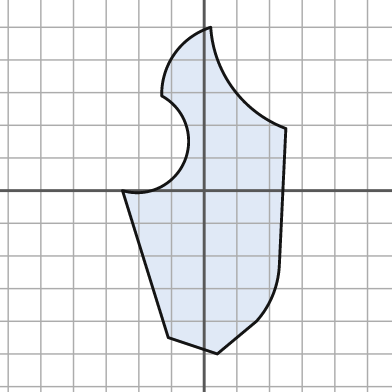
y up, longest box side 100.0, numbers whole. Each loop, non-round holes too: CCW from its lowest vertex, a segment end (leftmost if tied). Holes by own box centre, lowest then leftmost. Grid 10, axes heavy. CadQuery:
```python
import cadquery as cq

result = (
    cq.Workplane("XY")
    .moveTo(4.0, -50.0)
    .lineTo(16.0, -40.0)
    .threePointArc((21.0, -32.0), (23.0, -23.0))
    .lineTo(25.0, 19.0)
    .threePointArc((9.0, 31.0), (2.0, 50.0))
    .threePointArc((-9.0, 42.0), (-13.0, 29.0))
    .threePointArc((-6.0, 9.0), (-25.0, 0.0))
    .lineTo(-11.0, -45.0)
    .close()
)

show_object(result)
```